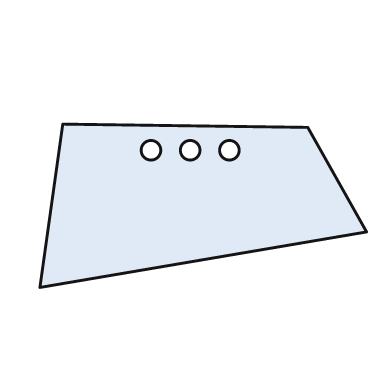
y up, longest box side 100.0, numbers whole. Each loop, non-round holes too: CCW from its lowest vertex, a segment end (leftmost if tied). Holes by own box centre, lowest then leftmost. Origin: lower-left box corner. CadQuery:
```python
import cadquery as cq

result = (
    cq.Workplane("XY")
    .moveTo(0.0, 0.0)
    .lineTo(100.0, 17.0)
    .lineTo(82.0, 49.0)
    .lineTo(7.0, 50.0)
    .close()
    .moveTo(34.0, 42.0)
    .circle(3.0)
    .moveTo(46.0, 42.0)
    .circle(3.0)
    .moveTo(58.0, 42.0)
    .circle(3.0)
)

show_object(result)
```